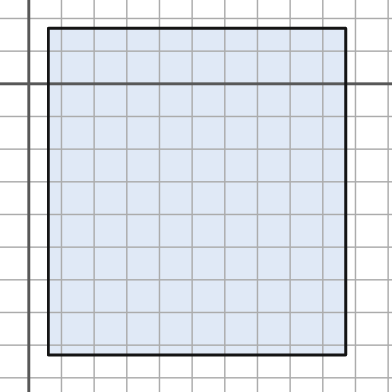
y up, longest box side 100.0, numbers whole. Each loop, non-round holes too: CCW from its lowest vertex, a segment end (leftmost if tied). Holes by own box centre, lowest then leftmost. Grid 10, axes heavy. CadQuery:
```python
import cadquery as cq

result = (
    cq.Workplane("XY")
    .moveTo(6.0, -83.0)
    .lineTo(97.0, -83.0)
    .lineTo(97.0, 17.0)
    .lineTo(6.0, 17.0)
    .close()
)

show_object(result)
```